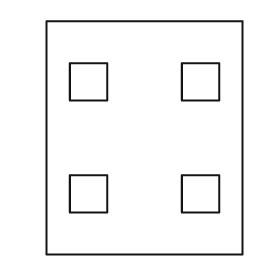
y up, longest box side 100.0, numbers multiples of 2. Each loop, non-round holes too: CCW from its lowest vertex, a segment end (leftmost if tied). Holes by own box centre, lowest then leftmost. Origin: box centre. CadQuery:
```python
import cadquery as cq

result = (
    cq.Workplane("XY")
    .moveTo(-42.0, -50.0)
    .lineTo(42.0, -50.0)
    .lineTo(42.0, 50.0)
    .lineTo(-42.0, 50.0)
    .close()
    .moveTo(-32.0, -32.0)
    .lineTo(-16.0, -32.0)
    .lineTo(-16.0, -16.0)
    .lineTo(-32.0, -16.0)
    .close()
    .moveTo(16.0, -32.0)
    .lineTo(32.0, -32.0)
    .lineTo(32.0, -16.0)
    .lineTo(16.0, -16.0)
    .close()
    .moveTo(-32.0, 16.0)
    .lineTo(-16.0, 16.0)
    .lineTo(-16.0, 32.0)
    .lineTo(-32.0, 32.0)
    .close()
    .moveTo(16.0, 16.0)
    .lineTo(32.0, 16.0)
    .lineTo(32.0, 32.0)
    .lineTo(16.0, 32.0)
    .close()
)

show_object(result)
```